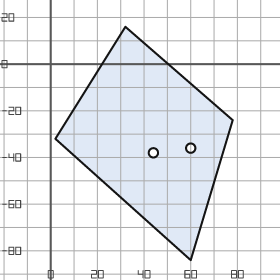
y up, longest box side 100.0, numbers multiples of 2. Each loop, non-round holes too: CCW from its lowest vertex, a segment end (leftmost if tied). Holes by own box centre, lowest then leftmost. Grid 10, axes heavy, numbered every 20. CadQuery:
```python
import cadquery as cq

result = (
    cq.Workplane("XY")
    .moveTo(60.0, -84.0)
    .lineTo(78.0, -24.0)
    .lineTo(32.0, 16.0)
    .lineTo(2.0, -32.0)
    .close()
    .moveTo(44.0, -38.0)
    .circle(2.0)
    .moveTo(60.0, -36.0)
    .circle(2.0)
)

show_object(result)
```